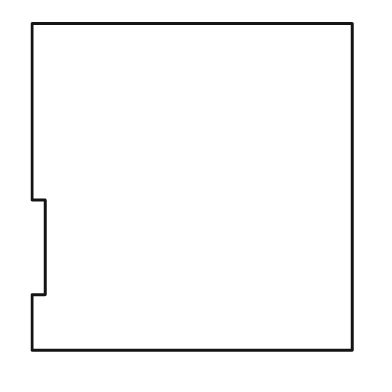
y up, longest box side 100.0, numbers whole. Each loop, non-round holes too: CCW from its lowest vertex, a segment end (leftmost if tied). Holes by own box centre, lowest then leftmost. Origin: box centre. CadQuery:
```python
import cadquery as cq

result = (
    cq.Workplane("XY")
    .moveTo(-49.0, -50.0)
    .lineTo(49.0, -50.0)
    .lineTo(49.0, 50.0)
    .lineTo(-49.0, 50.0)
    .lineTo(-49.0, -4.0)
    .lineTo(-45.0, -4.0)
    .lineTo(-45.0, -33.0)
    .lineTo(-49.0, -33.0)
    .close()
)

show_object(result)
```